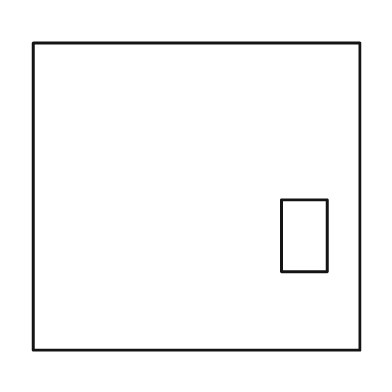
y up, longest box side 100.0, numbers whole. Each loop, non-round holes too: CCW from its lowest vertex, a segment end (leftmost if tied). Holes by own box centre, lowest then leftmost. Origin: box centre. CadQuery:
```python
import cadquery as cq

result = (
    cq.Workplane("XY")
    .moveTo(-50.0, -47.0)
    .lineTo(50.0, -47.0)
    .lineTo(50.0, 47.0)
    .lineTo(-50.0, 47.0)
    .close()
    .moveTo(26.0, -23.0)
    .lineTo(40.0, -23.0)
    .lineTo(40.0, -1.0)
    .lineTo(26.0, -1.0)
    .close()
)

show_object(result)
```